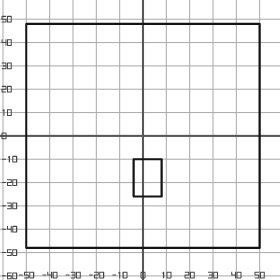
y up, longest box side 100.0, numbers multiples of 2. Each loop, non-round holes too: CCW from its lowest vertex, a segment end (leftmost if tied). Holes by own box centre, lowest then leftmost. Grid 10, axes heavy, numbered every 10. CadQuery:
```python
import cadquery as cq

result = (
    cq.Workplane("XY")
    .moveTo(-50.0, -48.0)
    .lineTo(50.0, -48.0)
    .lineTo(50.0, 48.0)
    .lineTo(-50.0, 48.0)
    .close()
    .moveTo(-4.0, -26.0)
    .lineTo(8.0, -26.0)
    .lineTo(8.0, -10.0)
    .lineTo(-4.0, -10.0)
    .close()
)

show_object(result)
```